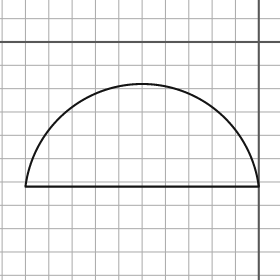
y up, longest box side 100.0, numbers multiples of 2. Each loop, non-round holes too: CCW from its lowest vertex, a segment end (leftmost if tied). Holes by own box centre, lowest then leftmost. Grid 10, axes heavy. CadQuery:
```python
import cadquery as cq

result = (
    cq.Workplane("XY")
    .moveTo(-100.0, -62.0)
    .lineTo(0.0, -62.0)
    .threePointArc((-50.0, -18.0), (-100.0, -62.0))
    .close()
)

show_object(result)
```